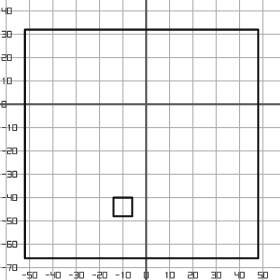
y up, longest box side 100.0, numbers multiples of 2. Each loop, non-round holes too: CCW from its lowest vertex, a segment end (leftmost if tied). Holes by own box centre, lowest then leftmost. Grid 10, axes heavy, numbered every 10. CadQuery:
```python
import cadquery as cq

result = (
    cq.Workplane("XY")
    .moveTo(-52.0, -66.0)
    .lineTo(48.0, -66.0)
    .lineTo(48.0, 32.0)
    .lineTo(-52.0, 32.0)
    .close()
    .moveTo(-14.0, -48.0)
    .lineTo(-6.0, -48.0)
    .lineTo(-6.0, -40.0)
    .lineTo(-14.0, -40.0)
    .close()
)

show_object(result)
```